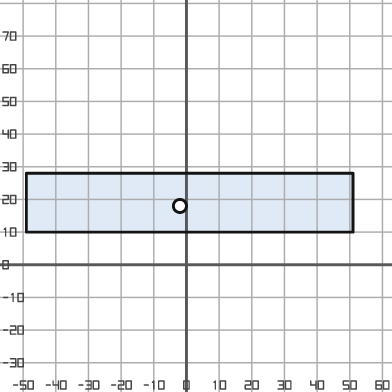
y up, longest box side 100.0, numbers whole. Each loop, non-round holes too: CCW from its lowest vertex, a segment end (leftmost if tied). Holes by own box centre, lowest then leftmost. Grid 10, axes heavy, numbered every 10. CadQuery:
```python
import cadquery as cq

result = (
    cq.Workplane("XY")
    .moveTo(-49.0, 10.0)
    .lineTo(51.0, 10.0)
    .lineTo(51.0, 28.0)
    .lineTo(-49.0, 28.0)
    .close()
    .moveTo(-2.0, 18.0)
    .circle(2.0)
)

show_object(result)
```